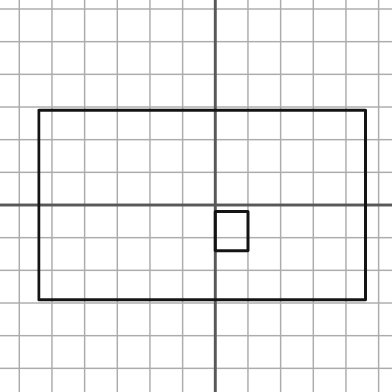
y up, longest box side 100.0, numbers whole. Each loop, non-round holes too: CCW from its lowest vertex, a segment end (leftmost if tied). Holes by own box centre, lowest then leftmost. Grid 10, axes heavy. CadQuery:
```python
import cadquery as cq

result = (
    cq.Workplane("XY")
    .moveTo(-54.0, -29.0)
    .lineTo(46.0, -29.0)
    .lineTo(46.0, 29.0)
    .lineTo(-54.0, 29.0)
    .close()
    .moveTo(0.0, -14.0)
    .lineTo(10.0, -14.0)
    .lineTo(10.0, -2.0)
    .lineTo(0.0, -2.0)
    .close()
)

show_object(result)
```